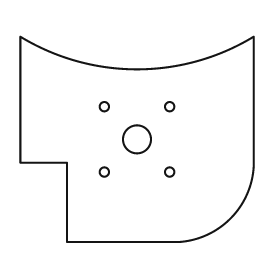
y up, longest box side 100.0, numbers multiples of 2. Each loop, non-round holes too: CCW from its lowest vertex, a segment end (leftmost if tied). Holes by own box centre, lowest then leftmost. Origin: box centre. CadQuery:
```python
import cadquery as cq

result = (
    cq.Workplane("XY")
    .moveTo(-30.0, -44.0)
    .lineTo(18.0, -44.0)
    .threePointArc((40.0, -34.0), (50.0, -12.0))
    .lineTo(50.0, 44.0)
    .threePointArc((0.0, 30.0), (-50.0, 44.0))
    .lineTo(-50.0, -10.0)
    .lineTo(-30.0, -10.0)
    .close()
    .moveTo(-14.0, -14.0)
    .circle(2.0)
    .moveTo(14.0, -14.0)
    .circle(2.0)
    .moveTo(0.0, 0.0)
    .circle(6.0)
    .moveTo(-14.0, 14.0)
    .circle(2.0)
    .moveTo(14.0, 14.0)
    .circle(2.0)
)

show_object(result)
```